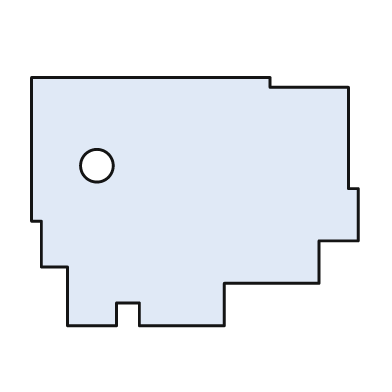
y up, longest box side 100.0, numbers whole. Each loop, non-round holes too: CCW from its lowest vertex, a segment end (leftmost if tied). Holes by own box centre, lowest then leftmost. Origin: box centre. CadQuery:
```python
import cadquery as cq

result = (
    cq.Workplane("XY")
    .moveTo(-39.0, -38.0)
    .lineTo(-24.0, -38.0)
    .lineTo(-24.0, -31.0)
    .lineTo(-17.0, -31.0)
    .lineTo(-17.0, -38.0)
    .lineTo(9.0, -38.0)
    .lineTo(9.0, -25.0)
    .lineTo(38.0, -25.0)
    .lineTo(38.0, -12.0)
    .lineTo(50.0, -12.0)
    .lineTo(50.0, 4.0)
    .lineTo(47.0, 4.0)
    .lineTo(47.0, 35.0)
    .lineTo(23.0, 35.0)
    .lineTo(23.0, 38.0)
    .lineTo(-50.0, 38.0)
    .lineTo(-50.0, -6.0)
    .lineTo(-47.0, -6.0)
    .lineTo(-47.0, -20.0)
    .lineTo(-39.0, -20.0)
    .close()
    .moveTo(-30.0, 11.0)
    .circle(5.0)
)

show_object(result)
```